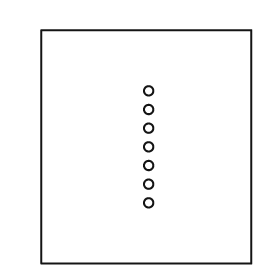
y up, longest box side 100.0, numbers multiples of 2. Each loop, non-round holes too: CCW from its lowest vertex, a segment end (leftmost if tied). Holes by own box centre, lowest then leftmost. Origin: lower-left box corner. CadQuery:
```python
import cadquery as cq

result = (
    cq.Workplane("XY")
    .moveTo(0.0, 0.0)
    .lineTo(90.0, 0.0)
    .lineTo(90.0, 100.0)
    .lineTo(0.0, 100.0)
    .close()
    .moveTo(46.0, 26.0)
    .circle(2.0)
    .moveTo(46.0, 34.0)
    .circle(2.0)
    .moveTo(46.0, 42.0)
    .circle(2.0)
    .moveTo(46.0, 50.0)
    .circle(2.0)
    .moveTo(46.0, 58.0)
    .circle(2.0)
    .moveTo(46.0, 66.0)
    .circle(2.0)
    .moveTo(46.0, 74.0)
    .circle(2.0)
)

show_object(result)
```